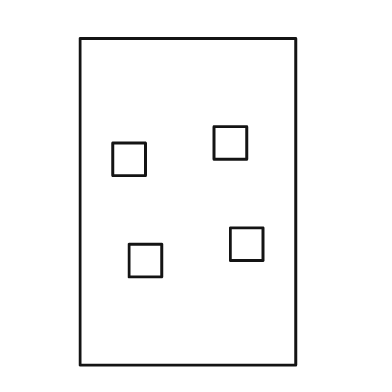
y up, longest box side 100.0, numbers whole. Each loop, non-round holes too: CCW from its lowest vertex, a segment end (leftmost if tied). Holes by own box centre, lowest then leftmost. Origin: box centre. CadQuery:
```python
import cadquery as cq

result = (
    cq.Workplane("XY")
    .moveTo(-33.0, -50.0)
    .lineTo(33.0, -50.0)
    .lineTo(33.0, 50.0)
    .lineTo(-33.0, 50.0)
    .close()
    .moveTo(-18.0, -23.0)
    .lineTo(-8.0, -23.0)
    .lineTo(-8.0, -13.0)
    .lineTo(-18.0, -13.0)
    .close()
    .moveTo(13.0, -18.0)
    .lineTo(23.0, -18.0)
    .lineTo(23.0, -8.0)
    .lineTo(13.0, -8.0)
    .close()
    .moveTo(-23.0, 8.0)
    .lineTo(-13.0, 8.0)
    .lineTo(-13.0, 18.0)
    .lineTo(-23.0, 18.0)
    .close()
    .moveTo(8.0, 13.0)
    .lineTo(18.0, 13.0)
    .lineTo(18.0, 23.0)
    .lineTo(8.0, 23.0)
    .close()
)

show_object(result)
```